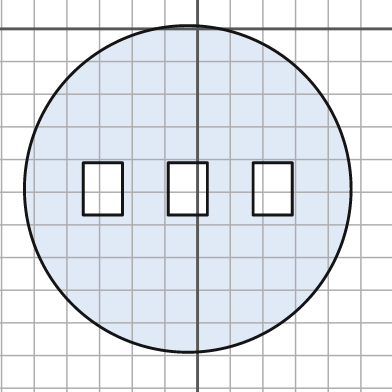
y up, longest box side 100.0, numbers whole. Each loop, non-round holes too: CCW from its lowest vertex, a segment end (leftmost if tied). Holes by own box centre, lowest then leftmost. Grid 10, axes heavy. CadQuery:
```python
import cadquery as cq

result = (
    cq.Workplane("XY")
    .moveTo(-3.0, -49.0)
    .circle(50.0)
    .moveTo(-35.0, -57.0)
    .lineTo(-23.0, -57.0)
    .lineTo(-23.0, -41.0)
    .lineTo(-35.0, -41.0)
    .close()
    .moveTo(-9.0, -57.0)
    .lineTo(3.0, -57.0)
    .lineTo(3.0, -41.0)
    .lineTo(-9.0, -41.0)
    .close()
    .moveTo(17.0, -57.0)
    .lineTo(29.0, -57.0)
    .lineTo(29.0, -41.0)
    .lineTo(17.0, -41.0)
    .close()
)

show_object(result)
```